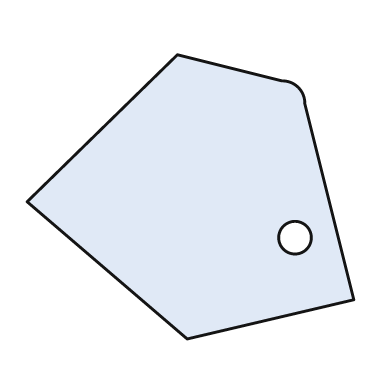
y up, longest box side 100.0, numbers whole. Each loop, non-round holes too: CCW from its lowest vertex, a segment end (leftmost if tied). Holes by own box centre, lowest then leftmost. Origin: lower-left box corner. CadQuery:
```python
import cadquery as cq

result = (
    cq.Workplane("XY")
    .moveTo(49.0, 0.0)
    .lineTo(100.0, 12.0)
    .lineTo(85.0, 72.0)
    .threePointArc((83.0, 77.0), (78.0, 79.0))
    .lineTo(46.0, 87.0)
    .lineTo(0.0, 42.0)
    .close()
    .moveTo(82.0, 31.0)
    .circle(5.0)
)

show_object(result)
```